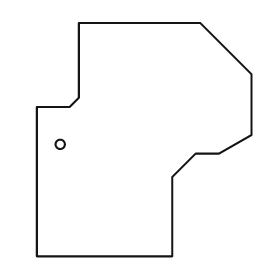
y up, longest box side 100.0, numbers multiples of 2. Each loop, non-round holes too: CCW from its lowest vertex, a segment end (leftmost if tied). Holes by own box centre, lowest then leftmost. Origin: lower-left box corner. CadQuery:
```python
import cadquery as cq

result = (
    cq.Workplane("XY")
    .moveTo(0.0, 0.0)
    .lineTo(58.0, 0.0)
    .lineTo(58.0, 34.0)
    .lineTo(68.0, 44.0)
    .lineTo(78.0, 44.0)
    .lineTo(92.0, 52.0)
    .lineTo(92.0, 78.0)
    .lineTo(70.0, 100.0)
    .lineTo(18.0, 100.0)
    .lineTo(18.0, 68.0)
    .lineTo(14.0, 64.0)
    .lineTo(0.0, 64.0)
    .close()
    .moveTo(10.0, 48.0)
    .circle(2.0)
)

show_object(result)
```